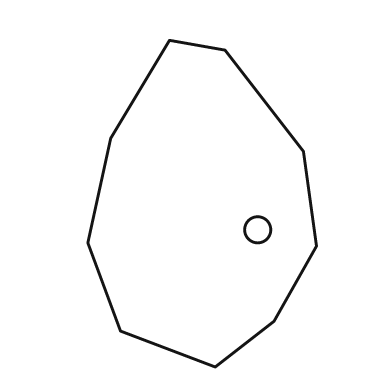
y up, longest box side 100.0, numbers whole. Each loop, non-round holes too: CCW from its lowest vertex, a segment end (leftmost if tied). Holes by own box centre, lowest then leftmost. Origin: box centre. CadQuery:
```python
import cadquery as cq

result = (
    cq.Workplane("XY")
    .moveTo(4.0, -50.0)
    .lineTo(22.0, -36.0)
    .lineTo(35.0, -13.0)
    .lineTo(31.0, 16.0)
    .lineTo(7.0, 47.0)
    .lineTo(-10.0, 50.0)
    .lineTo(-28.0, 20.0)
    .lineTo(-35.0, -12.0)
    .lineTo(-25.0, -39.0)
    .close()
    .moveTo(17.0, -8.0)
    .circle(4.0)
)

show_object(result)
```